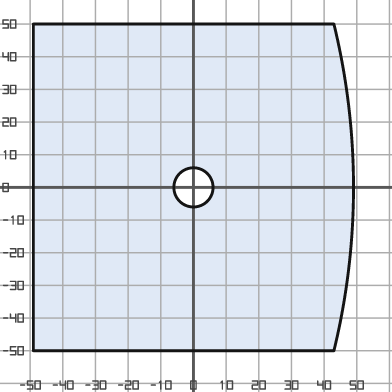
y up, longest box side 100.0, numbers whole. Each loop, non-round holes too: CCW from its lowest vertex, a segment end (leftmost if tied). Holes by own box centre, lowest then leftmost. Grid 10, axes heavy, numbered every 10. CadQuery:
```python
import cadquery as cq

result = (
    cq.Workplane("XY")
    .moveTo(-49.0, -50.0)
    .lineTo(43.0, -50.0)
    .threePointArc((49.0, 0.0), (43.0, 50.0))
    .lineTo(-49.0, 50.0)
    .close()
    .moveTo(0.0, 0.0)
    .circle(6.0)
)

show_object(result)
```